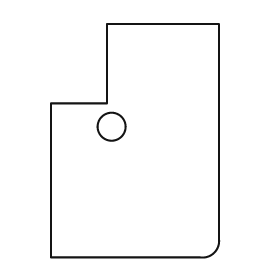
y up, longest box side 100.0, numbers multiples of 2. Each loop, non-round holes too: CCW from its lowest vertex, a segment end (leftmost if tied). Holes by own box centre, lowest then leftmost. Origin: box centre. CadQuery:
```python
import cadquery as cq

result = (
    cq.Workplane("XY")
    .moveTo(-36.0, -50.0)
    .lineTo(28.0, -50.0)
    .threePointArc((34.0, -48.0), (36.0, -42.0))
    .lineTo(36.0, 50.0)
    .lineTo(-12.0, 50.0)
    .lineTo(-12.0, 16.0)
    .lineTo(-36.0, 16.0)
    .close()
    .moveTo(-10.0, 6.0)
    .circle(6.0)
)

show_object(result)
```